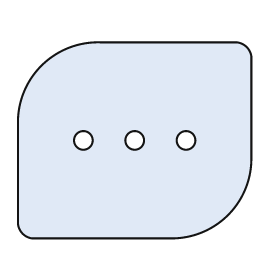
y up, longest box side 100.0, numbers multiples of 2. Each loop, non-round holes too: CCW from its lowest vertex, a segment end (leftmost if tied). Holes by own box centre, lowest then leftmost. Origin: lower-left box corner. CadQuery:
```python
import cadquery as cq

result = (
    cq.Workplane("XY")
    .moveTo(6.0, 0.0)
    .lineTo(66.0, 0.0)
    .threePointArc((90.0, 10.0), (100.0, 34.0))
    .lineTo(100.0, 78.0)
    .threePointArc((98.0, 82.0), (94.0, 84.0))
    .lineTo(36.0, 84.0)
    .threePointArc((10.0, 74.0), (0.0, 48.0))
    .lineTo(0.0, 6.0)
    .threePointArc((2.0, 2.0), (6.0, 0.0))
    .close()
    .moveTo(28.0, 42.0)
    .circle(4.0)
    .moveTo(50.0, 42.0)
    .circle(4.0)
    .moveTo(72.0, 42.0)
    .circle(4.0)
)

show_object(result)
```